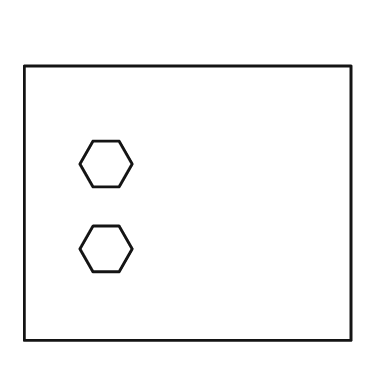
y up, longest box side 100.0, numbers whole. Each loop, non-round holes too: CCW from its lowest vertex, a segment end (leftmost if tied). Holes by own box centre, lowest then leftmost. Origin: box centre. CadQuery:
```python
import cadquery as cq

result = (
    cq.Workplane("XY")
    .moveTo(-50.0, -42.0)
    .lineTo(50.0, -42.0)
    .lineTo(50.0, 42.0)
    .lineTo(-50.0, 42.0)
    .close()
    .moveTo(-29.0, -21.0)
    .lineTo(-21.0, -21.0)
    .lineTo(-17.0, -14.0)
    .lineTo(-21.0, -7.0)
    .lineTo(-29.0, -7.0)
    .lineTo(-33.0, -14.0)
    .close()
    .moveTo(-29.0, 5.0)
    .lineTo(-21.0, 5.0)
    .lineTo(-17.0, 12.0)
    .lineTo(-21.0, 19.0)
    .lineTo(-29.0, 19.0)
    .lineTo(-33.0, 12.0)
    .close()
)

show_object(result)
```